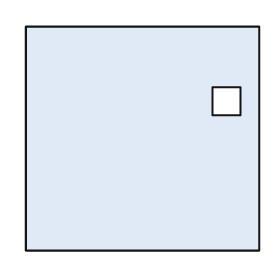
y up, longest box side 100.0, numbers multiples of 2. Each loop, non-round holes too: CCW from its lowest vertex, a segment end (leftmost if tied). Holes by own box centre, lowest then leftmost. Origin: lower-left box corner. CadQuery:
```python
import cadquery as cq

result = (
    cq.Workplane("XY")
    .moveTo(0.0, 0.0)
    .lineTo(100.0, 0.0)
    .lineTo(100.0, 96.0)
    .lineTo(0.0, 96.0)
    .close()
    .moveTo(80.0, 58.0)
    .lineTo(92.0, 58.0)
    .lineTo(92.0, 70.0)
    .lineTo(80.0, 70.0)
    .close()
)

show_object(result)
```